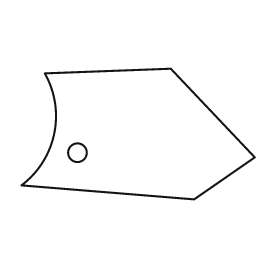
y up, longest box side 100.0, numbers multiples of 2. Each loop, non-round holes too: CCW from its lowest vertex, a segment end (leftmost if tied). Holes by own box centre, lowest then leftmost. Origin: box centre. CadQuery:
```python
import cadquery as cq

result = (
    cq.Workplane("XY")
    .moveTo(24.0, -28.0)
    .lineTo(50.0, -10.0)
    .lineTo(14.0, 28.0)
    .lineTo(-40.0, 26.0)
    .threePointArc((-36.0, 0.0), (-50.0, -22.0))
    .close()
    .moveTo(-26.0, -8.0)
    .circle(4.0)
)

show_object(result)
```